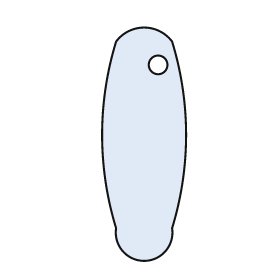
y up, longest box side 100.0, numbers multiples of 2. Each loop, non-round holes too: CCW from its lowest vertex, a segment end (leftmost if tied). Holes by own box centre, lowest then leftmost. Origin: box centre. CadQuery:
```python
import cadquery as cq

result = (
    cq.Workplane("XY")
    .moveTo(-12.0, -36.0)
    .threePointArc((0.0, -50.0), (12.0, -36.0))
    .threePointArc((18.0, 4.0), (12.0, 44.0))
    .threePointArc((0.0, 50.0), (-12.0, 44.0))
    .threePointArc((-18.0, 4.0), (-12.0, -36.0))
    .close()
    .moveTo(6.0, 34.0)
    .circle(4.0)
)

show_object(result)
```